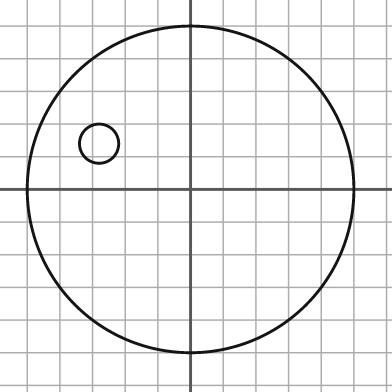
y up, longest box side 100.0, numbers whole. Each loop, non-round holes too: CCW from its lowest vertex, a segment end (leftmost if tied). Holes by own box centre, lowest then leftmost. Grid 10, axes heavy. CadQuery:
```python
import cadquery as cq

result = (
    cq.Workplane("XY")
    .moveTo(0.0, 0.0)
    .circle(50.0)
    .moveTo(-28.0, 14.0)
    .circle(6.0)
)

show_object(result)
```